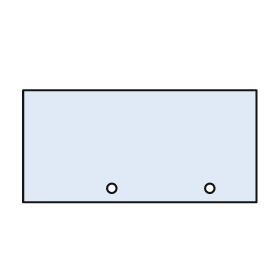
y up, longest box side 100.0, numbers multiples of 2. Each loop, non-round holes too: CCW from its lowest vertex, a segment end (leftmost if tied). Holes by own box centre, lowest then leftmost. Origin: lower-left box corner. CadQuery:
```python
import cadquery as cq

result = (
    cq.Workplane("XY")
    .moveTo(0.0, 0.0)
    .lineTo(100.0, 0.0)
    .lineTo(100.0, 48.0)
    .lineTo(0.0, 48.0)
    .close()
    .moveTo(38.0, 6.0)
    .circle(2.0)
    .moveTo(80.0, 6.0)
    .circle(2.0)
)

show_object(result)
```